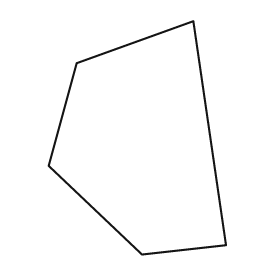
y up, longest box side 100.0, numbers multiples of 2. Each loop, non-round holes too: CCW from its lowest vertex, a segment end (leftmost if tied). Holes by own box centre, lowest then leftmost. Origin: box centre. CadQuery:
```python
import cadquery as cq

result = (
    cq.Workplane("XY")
    .moveTo(2.0, -50.0)
    .lineTo(38.0, -46.0)
    .lineTo(24.0, 50.0)
    .lineTo(-26.0, 32.0)
    .lineTo(-38.0, -12.0)
    .close()
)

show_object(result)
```